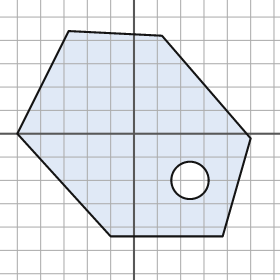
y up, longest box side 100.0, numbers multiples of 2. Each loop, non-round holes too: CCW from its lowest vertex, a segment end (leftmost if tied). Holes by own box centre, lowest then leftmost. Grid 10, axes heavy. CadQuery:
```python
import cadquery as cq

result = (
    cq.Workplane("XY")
    .moveTo(-10.0, -44.0)
    .lineTo(38.0, -44.0)
    .lineTo(50.0, -2.0)
    .lineTo(12.0, 42.0)
    .lineTo(-28.0, 44.0)
    .lineTo(-50.0, 0.0)
    .close()
    .moveTo(24.0, -20.0)
    .circle(8.0)
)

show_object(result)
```